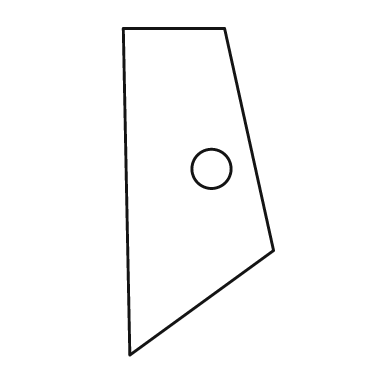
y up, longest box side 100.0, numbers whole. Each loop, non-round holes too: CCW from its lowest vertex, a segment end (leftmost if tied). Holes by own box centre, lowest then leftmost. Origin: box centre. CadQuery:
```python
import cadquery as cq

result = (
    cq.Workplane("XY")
    .moveTo(-21.0, -50.0)
    .lineTo(23.0, -18.0)
    .lineTo(8.0, 50.0)
    .lineTo(-23.0, 50.0)
    .close()
    .moveTo(4.0, 7.0)
    .circle(6.0)
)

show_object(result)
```